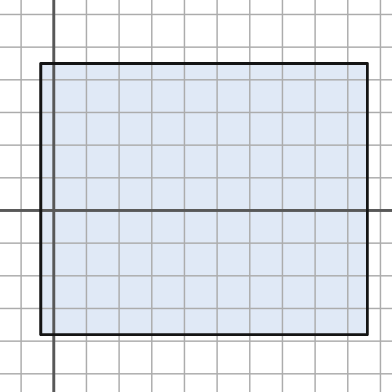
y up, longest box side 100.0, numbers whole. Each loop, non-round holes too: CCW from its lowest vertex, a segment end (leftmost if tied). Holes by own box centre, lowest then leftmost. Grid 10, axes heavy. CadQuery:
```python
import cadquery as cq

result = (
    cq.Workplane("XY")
    .moveTo(-4.0, -38.0)
    .lineTo(96.0, -38.0)
    .lineTo(96.0, 45.0)
    .lineTo(-4.0, 45.0)
    .close()
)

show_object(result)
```